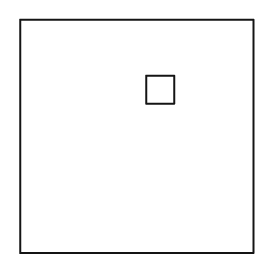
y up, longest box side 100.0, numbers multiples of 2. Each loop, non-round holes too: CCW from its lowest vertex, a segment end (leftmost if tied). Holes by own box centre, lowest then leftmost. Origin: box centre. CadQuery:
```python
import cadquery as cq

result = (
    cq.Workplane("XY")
    .moveTo(-50.0, -50.0)
    .lineTo(50.0, -50.0)
    .lineTo(50.0, 50.0)
    .lineTo(-50.0, 50.0)
    .close()
    .moveTo(4.0, 14.0)
    .lineTo(16.0, 14.0)
    .lineTo(16.0, 26.0)
    .lineTo(4.0, 26.0)
    .close()
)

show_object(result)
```